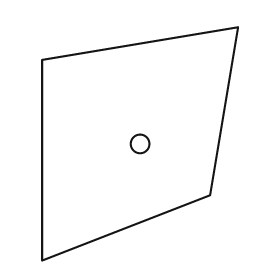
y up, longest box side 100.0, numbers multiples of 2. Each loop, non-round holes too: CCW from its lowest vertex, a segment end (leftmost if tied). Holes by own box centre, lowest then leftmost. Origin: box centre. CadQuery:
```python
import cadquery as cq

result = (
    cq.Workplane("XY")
    .moveTo(-42.0, -50.0)
    .lineTo(30.0, -22.0)
    .lineTo(42.0, 50.0)
    .lineTo(-42.0, 36.0)
    .close()
    .moveTo(0.0, 0.0)
    .circle(4.0)
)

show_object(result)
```